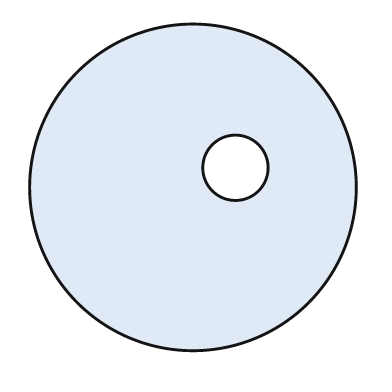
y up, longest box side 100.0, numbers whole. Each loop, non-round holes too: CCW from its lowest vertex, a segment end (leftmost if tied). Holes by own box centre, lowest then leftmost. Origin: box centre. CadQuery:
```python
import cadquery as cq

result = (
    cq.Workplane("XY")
    .moveTo(0.0, 0.0)
    .circle(50.0)
    .moveTo(13.0, 6.0)
    .circle(10.0)
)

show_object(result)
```